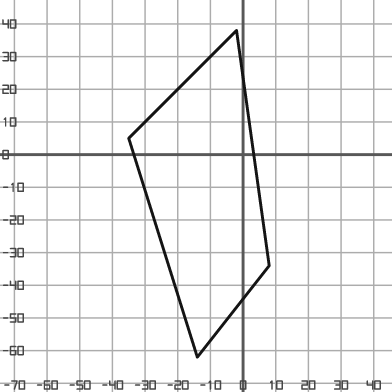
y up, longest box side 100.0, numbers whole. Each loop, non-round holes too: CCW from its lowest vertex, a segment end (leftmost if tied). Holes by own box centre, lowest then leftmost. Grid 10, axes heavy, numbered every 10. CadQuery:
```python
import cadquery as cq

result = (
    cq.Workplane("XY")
    .moveTo(-14.0, -62.0)
    .lineTo(8.0, -34.0)
    .lineTo(-2.0, 38.0)
    .lineTo(-35.0, 5.0)
    .close()
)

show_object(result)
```